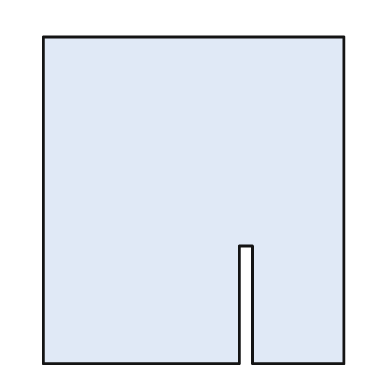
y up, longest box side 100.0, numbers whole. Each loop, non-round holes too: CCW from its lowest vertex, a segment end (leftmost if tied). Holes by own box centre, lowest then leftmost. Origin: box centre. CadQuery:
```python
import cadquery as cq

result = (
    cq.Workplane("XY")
    .moveTo(-46.0, -50.0)
    .lineTo(14.0, -50.0)
    .lineTo(14.0, -14.0)
    .lineTo(18.0, -14.0)
    .lineTo(18.0, -50.0)
    .lineTo(46.0, -50.0)
    .lineTo(46.0, 50.0)
    .lineTo(-46.0, 50.0)
    .close()
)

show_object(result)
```